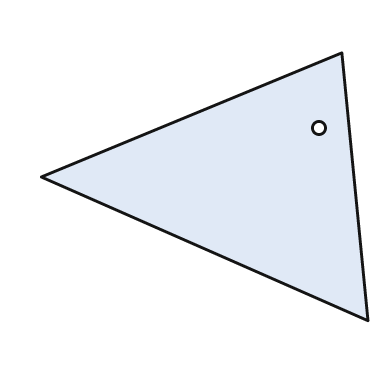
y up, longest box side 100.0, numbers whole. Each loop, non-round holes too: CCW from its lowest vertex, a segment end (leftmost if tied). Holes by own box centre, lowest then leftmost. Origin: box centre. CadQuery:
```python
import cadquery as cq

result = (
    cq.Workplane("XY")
    .moveTo(50.0, -41.0)
    .lineTo(42.0, 41.0)
    .lineTo(-50.0, 3.0)
    .close()
    .moveTo(35.0, 18.0)
    .circle(2.0)
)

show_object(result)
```